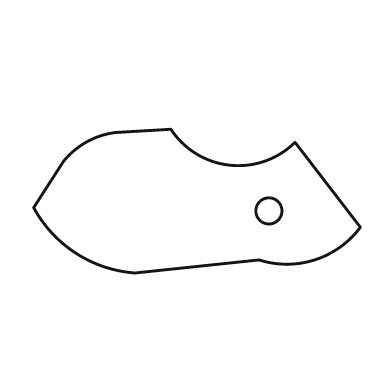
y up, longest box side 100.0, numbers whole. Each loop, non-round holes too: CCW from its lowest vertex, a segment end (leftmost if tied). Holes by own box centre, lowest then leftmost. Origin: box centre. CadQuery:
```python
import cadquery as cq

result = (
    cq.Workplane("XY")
    .moveTo(-19.0, -22.0)
    .lineTo(19.0, -18.0)
    .threePointArc((36.0, -18.0), (50.0, -8.0))
    .lineTo(30.0, 18.0)
    .threePointArc((10.0, 11.0), (-8.0, 22.0))
    .lineTo(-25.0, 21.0)
    .threePointArc((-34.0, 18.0), (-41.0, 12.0))
    .lineTo(-50.0, -2.0)
    .threePointArc((-37.0, -16.0), (-19.0, -22.0))
    .close()
    .moveTo(22.0, -3.0)
    .circle(4.0)
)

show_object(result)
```